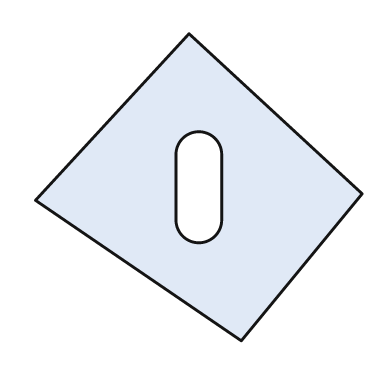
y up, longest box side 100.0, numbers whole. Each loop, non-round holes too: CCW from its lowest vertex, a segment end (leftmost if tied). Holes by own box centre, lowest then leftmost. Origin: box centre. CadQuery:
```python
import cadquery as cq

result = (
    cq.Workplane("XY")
    .moveTo(13.0, -47.0)
    .lineTo(50.0, -2.0)
    .lineTo(-3.0, 47.0)
    .lineTo(-50.0, -4.0)
    .close()
    .moveTo(-7.0, -10.0)
    .threePointArc((0.0, -17.0), (7.0, -10.0))
    .lineTo(7.0, 10.0)
    .threePointArc((0.0, 17.0), (-7.0, 10.0))
    .close()
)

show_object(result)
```